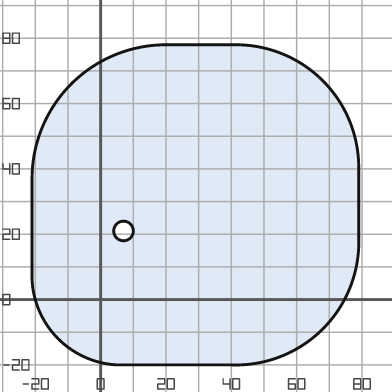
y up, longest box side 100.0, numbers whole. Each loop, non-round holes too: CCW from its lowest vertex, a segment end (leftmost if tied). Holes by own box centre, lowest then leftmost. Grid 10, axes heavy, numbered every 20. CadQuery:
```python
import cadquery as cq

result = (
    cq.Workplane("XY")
    .moveTo(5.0, -20.0)
    .lineTo(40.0, -20.0)
    .threePointArc((68.0, -9.0), (79.0, 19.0))
    .lineTo(79.0, 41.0)
    .threePointArc((68.0, 67.0), (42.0, 78.0))
    .lineTo(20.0, 78.0)
    .threePointArc((-9.0, 66.0), (-21.0, 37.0))
    .lineTo(-21.0, 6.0)
    .threePointArc((-13.0, -12.0), (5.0, -20.0))
    .close()
    .moveTo(7.0, 21.0)
    .circle(3.0)
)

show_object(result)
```